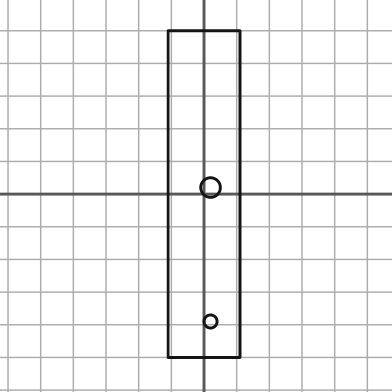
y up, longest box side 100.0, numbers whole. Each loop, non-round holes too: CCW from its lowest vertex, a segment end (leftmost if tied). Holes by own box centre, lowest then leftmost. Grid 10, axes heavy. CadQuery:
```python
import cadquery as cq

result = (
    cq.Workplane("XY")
    .moveTo(-11.0, -50.0)
    .lineTo(11.0, -50.0)
    .lineTo(11.0, 50.0)
    .lineTo(-11.0, 50.0)
    .close()
    .moveTo(2.0, -39.0)
    .circle(2.0)
    .moveTo(2.0, 2.0)
    .circle(3.0)
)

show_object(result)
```